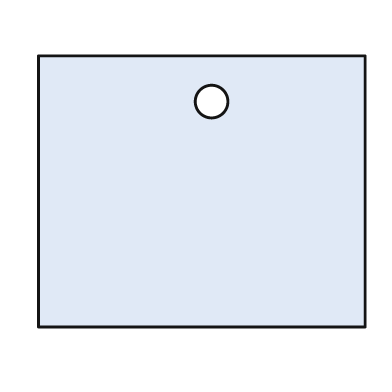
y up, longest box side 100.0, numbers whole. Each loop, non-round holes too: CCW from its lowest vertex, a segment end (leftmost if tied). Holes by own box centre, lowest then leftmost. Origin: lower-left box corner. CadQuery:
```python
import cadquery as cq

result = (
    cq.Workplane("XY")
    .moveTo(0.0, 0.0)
    .lineTo(100.0, 0.0)
    .lineTo(100.0, 83.0)
    .lineTo(0.0, 83.0)
    .close()
    .moveTo(53.0, 69.0)
    .circle(5.0)
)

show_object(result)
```